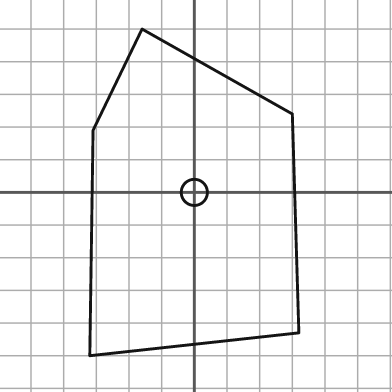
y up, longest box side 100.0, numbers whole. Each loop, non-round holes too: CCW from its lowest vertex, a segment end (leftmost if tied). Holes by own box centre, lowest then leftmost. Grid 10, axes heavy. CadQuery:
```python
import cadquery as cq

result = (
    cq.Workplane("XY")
    .moveTo(-32.0, -50.0)
    .lineTo(32.0, -43.0)
    .lineTo(30.0, 24.0)
    .lineTo(-16.0, 50.0)
    .lineTo(-31.0, 19.0)
    .close()
    .moveTo(0.0, 0.0)
    .circle(4.0)
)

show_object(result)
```